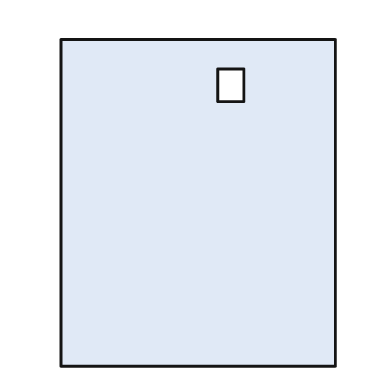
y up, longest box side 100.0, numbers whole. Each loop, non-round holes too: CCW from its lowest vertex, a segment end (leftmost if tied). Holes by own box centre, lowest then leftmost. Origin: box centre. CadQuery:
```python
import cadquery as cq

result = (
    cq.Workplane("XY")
    .moveTo(-42.0, -50.0)
    .lineTo(42.0, -50.0)
    .lineTo(42.0, 50.0)
    .lineTo(-42.0, 50.0)
    .close()
    .moveTo(6.0, 31.0)
    .lineTo(14.0, 31.0)
    .lineTo(14.0, 41.0)
    .lineTo(6.0, 41.0)
    .close()
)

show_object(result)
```